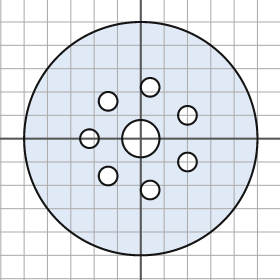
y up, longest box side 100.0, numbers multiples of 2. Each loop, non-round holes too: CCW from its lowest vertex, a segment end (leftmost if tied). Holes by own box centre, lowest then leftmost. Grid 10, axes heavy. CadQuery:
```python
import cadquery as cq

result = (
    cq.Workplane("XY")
    .moveTo(0.0, 0.0)
    .circle(50.0)
    .moveTo(4.0, -22.0)
    .circle(4.0)
    .moveTo(-14.0, -16.0)
    .circle(4.0)
    .moveTo(20.0, -10.0)
    .circle(4.0)
    .moveTo(-22.0, 0.0)
    .circle(4.0)
    .moveTo(0.0, 0.0)
    .circle(8.0)
    .moveTo(20.0, 10.0)
    .circle(4.0)
    .moveTo(-14.0, 16.0)
    .circle(4.0)
    .moveTo(4.0, 22.0)
    .circle(4.0)
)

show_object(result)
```